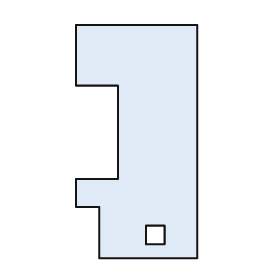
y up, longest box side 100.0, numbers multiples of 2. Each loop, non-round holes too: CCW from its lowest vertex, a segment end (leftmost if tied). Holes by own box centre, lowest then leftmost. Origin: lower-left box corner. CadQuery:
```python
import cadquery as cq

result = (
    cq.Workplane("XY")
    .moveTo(10.0, 0.0)
    .lineTo(52.0, 0.0)
    .lineTo(52.0, 100.0)
    .lineTo(0.0, 100.0)
    .lineTo(0.0, 74.0)
    .lineTo(18.0, 74.0)
    .lineTo(18.0, 34.0)
    .lineTo(0.0, 34.0)
    .lineTo(0.0, 22.0)
    .lineTo(10.0, 22.0)
    .close()
    .moveTo(30.0, 6.0)
    .lineTo(38.0, 6.0)
    .lineTo(38.0, 14.0)
    .lineTo(30.0, 14.0)
    .close()
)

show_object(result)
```